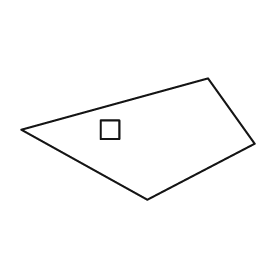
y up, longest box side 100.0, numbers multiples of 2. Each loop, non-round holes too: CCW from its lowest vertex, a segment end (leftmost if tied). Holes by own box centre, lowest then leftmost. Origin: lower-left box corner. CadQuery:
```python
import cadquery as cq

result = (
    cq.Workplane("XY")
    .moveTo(54.0, 0.0)
    .lineTo(100.0, 24.0)
    .lineTo(80.0, 52.0)
    .lineTo(0.0, 30.0)
    .close()
    .moveTo(34.0, 26.0)
    .lineTo(42.0, 26.0)
    .lineTo(42.0, 34.0)
    .lineTo(34.0, 34.0)
    .close()
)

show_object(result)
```